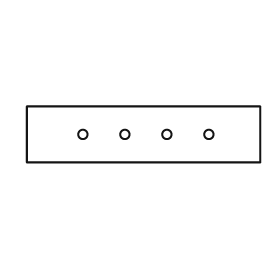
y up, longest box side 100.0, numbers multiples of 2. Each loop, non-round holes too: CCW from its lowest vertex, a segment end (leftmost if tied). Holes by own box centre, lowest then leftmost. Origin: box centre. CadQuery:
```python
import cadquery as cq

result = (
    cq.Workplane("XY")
    .moveTo(-50.0, -12.0)
    .lineTo(50.0, -12.0)
    .lineTo(50.0, 12.0)
    .lineTo(-50.0, 12.0)
    .close()
    .moveTo(-26.0, 0.0)
    .circle(2.0)
    .moveTo(-8.0, 0.0)
    .circle(2.0)
    .moveTo(10.0, 0.0)
    .circle(2.0)
    .moveTo(28.0, 0.0)
    .circle(2.0)
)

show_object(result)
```